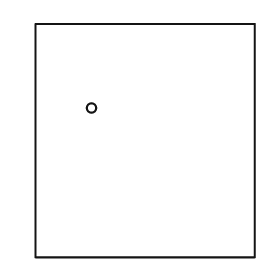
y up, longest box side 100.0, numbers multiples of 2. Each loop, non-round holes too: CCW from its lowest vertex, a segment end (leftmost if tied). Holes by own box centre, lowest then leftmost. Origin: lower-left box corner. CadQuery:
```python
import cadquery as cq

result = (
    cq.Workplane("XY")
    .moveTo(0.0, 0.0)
    .lineTo(94.0, 0.0)
    .lineTo(94.0, 100.0)
    .lineTo(0.0, 100.0)
    .close()
    .moveTo(24.0, 64.0)
    .circle(2.0)
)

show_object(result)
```